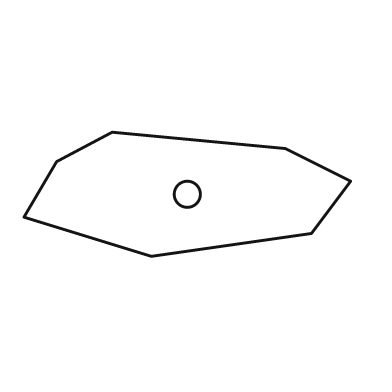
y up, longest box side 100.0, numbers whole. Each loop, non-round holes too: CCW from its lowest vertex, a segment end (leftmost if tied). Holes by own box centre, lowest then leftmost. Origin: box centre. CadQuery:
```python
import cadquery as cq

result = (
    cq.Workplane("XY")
    .moveTo(-11.0, -19.0)
    .lineTo(38.0, -12.0)
    .lineTo(50.0, 4.0)
    .lineTo(30.0, 14.0)
    .lineTo(-23.0, 19.0)
    .lineTo(-40.0, 10.0)
    .lineTo(-50.0, -7.0)
    .close()
    .moveTo(0.0, 0.0)
    .circle(4.0)
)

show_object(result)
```